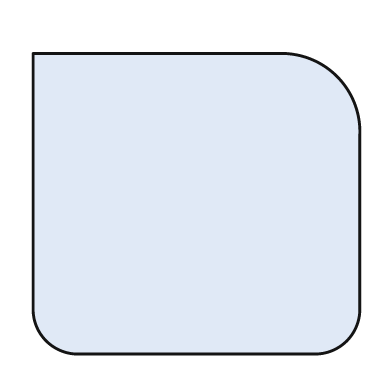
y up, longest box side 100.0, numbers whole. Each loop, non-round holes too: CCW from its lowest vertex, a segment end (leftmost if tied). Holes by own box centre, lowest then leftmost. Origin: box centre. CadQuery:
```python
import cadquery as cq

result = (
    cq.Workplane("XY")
    .moveTo(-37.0, -46.0)
    .lineTo(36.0, -46.0)
    .threePointArc((46.0, -42.0), (50.0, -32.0))
    .lineTo(50.0, 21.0)
    .threePointArc((43.0, 39.0), (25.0, 46.0))
    .lineTo(-50.0, 46.0)
    .lineTo(-50.0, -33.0)
    .threePointArc((-46.0, -42.0), (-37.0, -46.0))
    .close()
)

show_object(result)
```